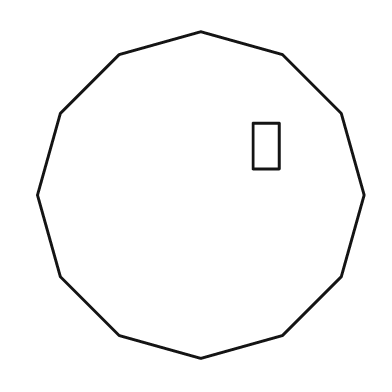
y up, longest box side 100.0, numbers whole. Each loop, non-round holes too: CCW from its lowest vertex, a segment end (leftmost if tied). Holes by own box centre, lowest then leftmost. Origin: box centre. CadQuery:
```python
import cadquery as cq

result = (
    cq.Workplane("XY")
    .moveTo(0.0, -50.0)
    .lineTo(25.0, -43.0)
    .lineTo(43.0, -25.0)
    .lineTo(50.0, 0.0)
    .lineTo(43.0, 25.0)
    .lineTo(25.0, 43.0)
    .lineTo(0.0, 50.0)
    .lineTo(-25.0, 43.0)
    .lineTo(-43.0, 25.0)
    .lineTo(-50.0, 0.0)
    .lineTo(-43.0, -25.0)
    .lineTo(-25.0, -43.0)
    .close()
    .moveTo(16.0, 8.0)
    .lineTo(24.0, 8.0)
    .lineTo(24.0, 22.0)
    .lineTo(16.0, 22.0)
    .close()
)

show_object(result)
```